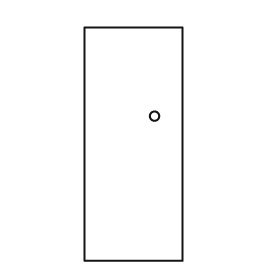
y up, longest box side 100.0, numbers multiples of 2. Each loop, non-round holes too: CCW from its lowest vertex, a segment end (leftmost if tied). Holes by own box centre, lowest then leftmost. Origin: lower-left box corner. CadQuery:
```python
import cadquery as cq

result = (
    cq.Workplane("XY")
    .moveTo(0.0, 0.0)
    .lineTo(42.0, 0.0)
    .lineTo(42.0, 100.0)
    .lineTo(0.0, 100.0)
    .close()
    .moveTo(30.0, 62.0)
    .circle(2.0)
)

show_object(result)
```